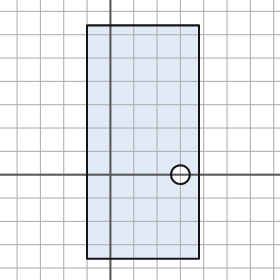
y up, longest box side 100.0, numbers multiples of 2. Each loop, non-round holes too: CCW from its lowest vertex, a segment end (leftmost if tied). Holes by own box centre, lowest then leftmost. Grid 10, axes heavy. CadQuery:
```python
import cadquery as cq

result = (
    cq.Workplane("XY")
    .moveTo(-10.0, -36.0)
    .lineTo(38.0, -36.0)
    .lineTo(38.0, 64.0)
    .lineTo(-10.0, 64.0)
    .close()
    .moveTo(30.0, 0.0)
    .circle(4.0)
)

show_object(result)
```